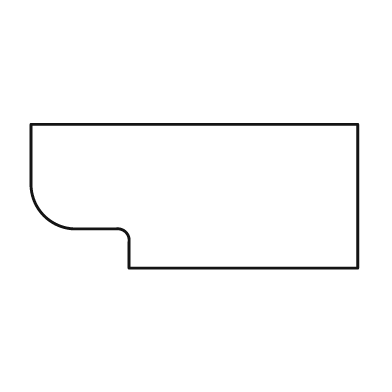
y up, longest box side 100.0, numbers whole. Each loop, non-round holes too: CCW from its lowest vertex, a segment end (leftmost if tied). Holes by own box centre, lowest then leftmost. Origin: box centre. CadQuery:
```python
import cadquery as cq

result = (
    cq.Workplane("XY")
    .moveTo(-20.0, -22.0)
    .lineTo(50.0, -22.0)
    .lineTo(50.0, 22.0)
    .lineTo(-50.0, 22.0)
    .lineTo(-50.0, 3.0)
    .threePointArc((-46.0, -6.0), (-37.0, -10.0))
    .lineTo(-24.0, -10.0)
    .threePointArc((-21.0, -11.0), (-20.0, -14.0))
    .close()
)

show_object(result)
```